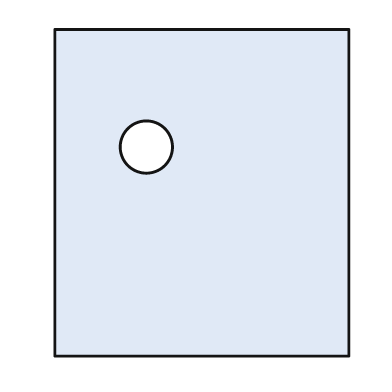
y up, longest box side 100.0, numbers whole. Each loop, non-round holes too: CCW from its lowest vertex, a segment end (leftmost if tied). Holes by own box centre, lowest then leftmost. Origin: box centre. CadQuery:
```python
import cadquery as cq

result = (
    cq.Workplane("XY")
    .moveTo(-45.0, -50.0)
    .lineTo(45.0, -50.0)
    .lineTo(45.0, 50.0)
    .lineTo(-45.0, 50.0)
    .close()
    .moveTo(-17.0, 14.0)
    .circle(8.0)
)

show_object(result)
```